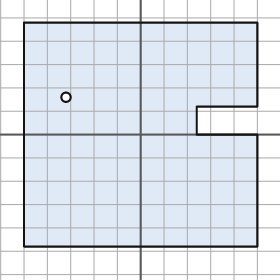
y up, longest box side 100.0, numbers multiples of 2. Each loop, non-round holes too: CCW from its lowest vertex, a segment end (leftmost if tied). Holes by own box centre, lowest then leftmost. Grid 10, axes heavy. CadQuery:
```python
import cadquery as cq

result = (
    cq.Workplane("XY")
    .moveTo(-50.0, -48.0)
    .lineTo(50.0, -48.0)
    .lineTo(50.0, 0.0)
    .lineTo(24.0, 0.0)
    .lineTo(24.0, 12.0)
    .lineTo(50.0, 12.0)
    .lineTo(50.0, 48.0)
    .lineTo(-50.0, 48.0)
    .close()
    .moveTo(-32.0, 16.0)
    .circle(2.0)
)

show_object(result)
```